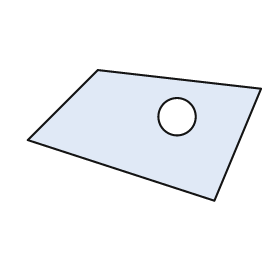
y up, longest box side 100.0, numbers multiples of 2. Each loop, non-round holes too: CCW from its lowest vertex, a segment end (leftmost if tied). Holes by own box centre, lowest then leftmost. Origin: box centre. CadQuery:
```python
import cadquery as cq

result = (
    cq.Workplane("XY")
    .moveTo(30.0, -28.0)
    .lineTo(50.0, 20.0)
    .lineTo(-20.0, 28.0)
    .lineTo(-50.0, -2.0)
    .close()
    .moveTo(14.0, 8.0)
    .circle(8.0)
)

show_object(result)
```